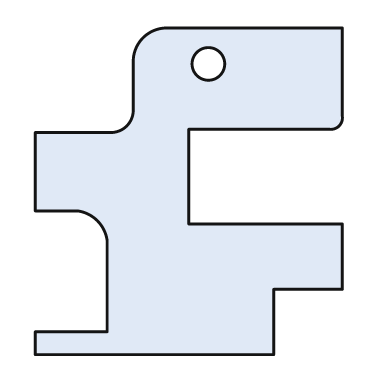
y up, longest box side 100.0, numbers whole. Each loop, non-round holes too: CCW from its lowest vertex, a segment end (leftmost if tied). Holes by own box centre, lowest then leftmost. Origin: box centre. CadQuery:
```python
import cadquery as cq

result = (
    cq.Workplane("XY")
    .moveTo(-47.0, -50.0)
    .lineTo(26.0, -50.0)
    .lineTo(26.0, -30.0)
    .lineTo(47.0, -30.0)
    .lineTo(47.0, -10.0)
    .lineTo(0.0, -10.0)
    .lineTo(0.0, 19.0)
    .lineTo(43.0, 19.0)
    .threePointArc((46.0, 20.0), (47.0, 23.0))
    .lineTo(47.0, 50.0)
    .lineTo(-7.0, 50.0)
    .threePointArc((-14.0, 47.0), (-17.0, 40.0))
    .lineTo(-17.0, 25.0)
    .threePointArc((-19.0, 20.0), (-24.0, 18.0))
    .lineTo(-47.0, 18.0)
    .lineTo(-47.0, -6.0)
    .lineTo(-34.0, -6.0)
    .threePointArc((-28.0, -9.0), (-25.0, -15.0))
    .lineTo(-25.0, -43.0)
    .lineTo(-47.0, -43.0)
    .close()
    .moveTo(6.0, 39.0)
    .circle(5.0)
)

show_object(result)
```